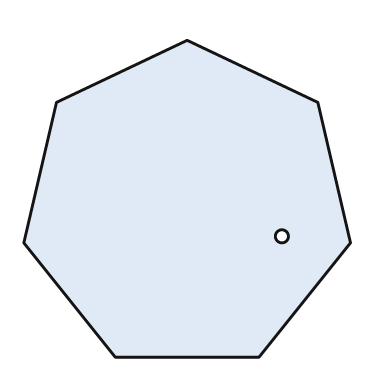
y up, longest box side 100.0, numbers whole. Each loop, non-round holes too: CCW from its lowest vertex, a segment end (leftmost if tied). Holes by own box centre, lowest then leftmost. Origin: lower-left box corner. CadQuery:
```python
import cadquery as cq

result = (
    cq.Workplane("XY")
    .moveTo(28.0, 0.0)
    .lineTo(72.0, 0.0)
    .lineTo(100.0, 35.0)
    .lineTo(90.0, 78.0)
    .lineTo(50.0, 97.0)
    .lineTo(10.0, 78.0)
    .lineTo(0.0, 35.0)
    .close()
    .moveTo(79.0, 37.0)
    .circle(2.0)
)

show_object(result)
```